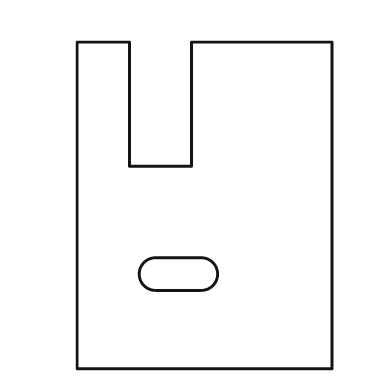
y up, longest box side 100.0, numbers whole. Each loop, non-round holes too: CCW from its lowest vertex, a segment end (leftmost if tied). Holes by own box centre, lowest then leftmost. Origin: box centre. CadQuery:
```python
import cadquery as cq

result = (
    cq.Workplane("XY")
    .moveTo(-39.0, -50.0)
    .lineTo(39.0, -50.0)
    .lineTo(39.0, 50.0)
    .lineTo(-4.0, 50.0)
    .lineTo(-4.0, 12.0)
    .lineTo(-23.0, 12.0)
    .lineTo(-23.0, 50.0)
    .lineTo(-39.0, 50.0)
    .close()
    .moveTo(-15.0, -26.0)
    .lineTo(-1.0, -26.0)
    .threePointArc((4.0, -21.0), (-1.0, -16.0))
    .lineTo(-15.0, -16.0)
    .threePointArc((-20.0, -21.0), (-15.0, -26.0))
    .close()
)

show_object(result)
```